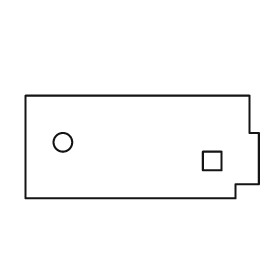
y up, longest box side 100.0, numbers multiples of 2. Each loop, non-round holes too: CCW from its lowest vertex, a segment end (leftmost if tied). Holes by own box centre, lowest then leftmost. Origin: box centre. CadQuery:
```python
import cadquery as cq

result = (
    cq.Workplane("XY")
    .moveTo(-50.0, -22.0)
    .lineTo(40.0, -22.0)
    .lineTo(40.0, -16.0)
    .lineTo(50.0, -16.0)
    .lineTo(50.0, 6.0)
    .lineTo(46.0, 6.0)
    .lineTo(46.0, 22.0)
    .lineTo(-50.0, 22.0)
    .close()
    .moveTo(26.0, -10.0)
    .lineTo(34.0, -10.0)
    .lineTo(34.0, -2.0)
    .lineTo(26.0, -2.0)
    .close()
    .moveTo(-34.0, 2.0)
    .circle(4.0)
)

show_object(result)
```